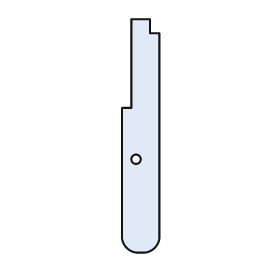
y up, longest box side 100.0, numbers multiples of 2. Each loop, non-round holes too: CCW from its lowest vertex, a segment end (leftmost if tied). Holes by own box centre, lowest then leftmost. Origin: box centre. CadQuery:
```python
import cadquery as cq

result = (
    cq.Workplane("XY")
    .moveTo(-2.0, -50.0)
    .lineTo(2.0, -50.0)
    .threePointArc((6.0, -48.0), (8.0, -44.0))
    .lineTo(8.0, 44.0)
    .lineTo(4.0, 44.0)
    .lineTo(4.0, 50.0)
    .lineTo(-4.0, 50.0)
    .lineTo(-4.0, 12.0)
    .lineTo(-8.0, 12.0)
    .lineTo(-8.0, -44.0)
    .threePointArc((-6.0, -48.0), (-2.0, -50.0))
    .close()
    .moveTo(-2.0, -10.0)
    .circle(2.0)
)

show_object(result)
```